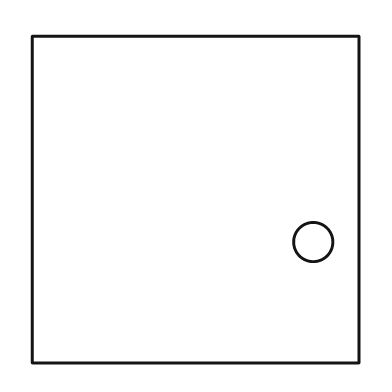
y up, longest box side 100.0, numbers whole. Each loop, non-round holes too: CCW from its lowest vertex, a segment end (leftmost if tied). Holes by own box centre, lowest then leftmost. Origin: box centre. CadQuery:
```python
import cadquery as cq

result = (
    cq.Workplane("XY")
    .moveTo(-50.0, -50.0)
    .lineTo(50.0, -50.0)
    .lineTo(50.0, 50.0)
    .lineTo(-50.0, 50.0)
    .close()
    .moveTo(36.0, -13.0)
    .circle(6.0)
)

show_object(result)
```